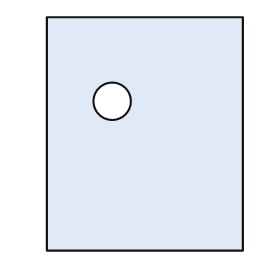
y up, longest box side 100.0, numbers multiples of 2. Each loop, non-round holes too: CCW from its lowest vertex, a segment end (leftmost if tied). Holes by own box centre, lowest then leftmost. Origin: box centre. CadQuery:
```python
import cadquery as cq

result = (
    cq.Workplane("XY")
    .moveTo(-42.0, -50.0)
    .lineTo(42.0, -50.0)
    .lineTo(42.0, 50.0)
    .lineTo(-42.0, 50.0)
    .close()
    .moveTo(-14.0, 14.0)
    .circle(8.0)
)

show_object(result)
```